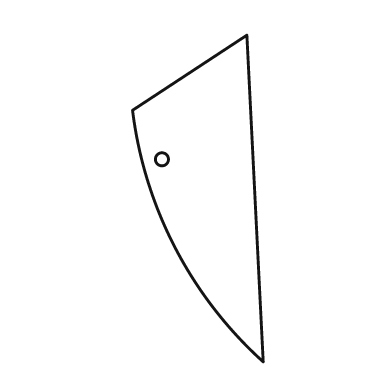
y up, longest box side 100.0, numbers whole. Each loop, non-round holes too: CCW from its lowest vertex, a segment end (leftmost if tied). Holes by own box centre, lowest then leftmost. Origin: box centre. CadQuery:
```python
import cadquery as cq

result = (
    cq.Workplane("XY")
    .moveTo(20.0, -50.0)
    .lineTo(15.0, 50.0)
    .lineTo(-20.0, 27.0)
    .threePointArc((-7.0, -15.0), (20.0, -50.0))
    .close()
    .moveTo(-11.0, 12.0)
    .circle(2.0)
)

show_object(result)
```